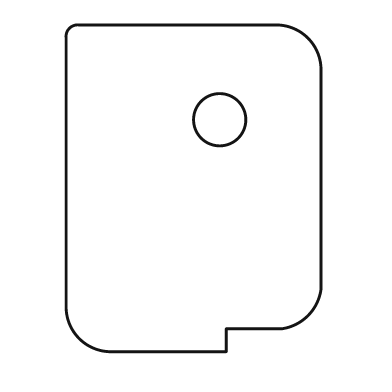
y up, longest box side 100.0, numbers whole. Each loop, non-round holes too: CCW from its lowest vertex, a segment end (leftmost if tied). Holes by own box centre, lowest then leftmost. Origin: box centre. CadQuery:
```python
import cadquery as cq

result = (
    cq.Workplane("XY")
    .moveTo(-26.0, -50.0)
    .lineTo(10.0, -50.0)
    .lineTo(10.0, -43.0)
    .lineTo(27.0, -43.0)
    .threePointArc((35.0, -39.0), (39.0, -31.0))
    .lineTo(39.0, 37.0)
    .threePointArc((35.0, 46.0), (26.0, 50.0))
    .lineTo(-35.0, 50.0)
    .threePointArc((-38.0, 49.0), (-39.0, 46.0))
    .lineTo(-39.0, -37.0)
    .threePointArc((-35.0, -46.0), (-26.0, -50.0))
    .close()
    .moveTo(8.0, 21.0)
    .circle(8.0)
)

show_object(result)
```